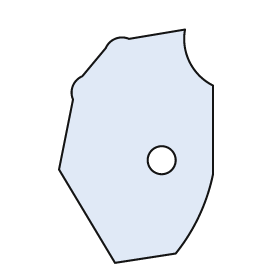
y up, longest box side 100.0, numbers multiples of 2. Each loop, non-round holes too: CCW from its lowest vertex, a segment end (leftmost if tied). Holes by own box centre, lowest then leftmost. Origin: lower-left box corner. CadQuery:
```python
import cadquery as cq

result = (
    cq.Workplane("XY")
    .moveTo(24.0, 0.0)
    .lineTo(50.0, 4.0)
    .threePointArc((60.0, 20.0), (66.0, 38.0))
    .lineTo(66.0, 76.0)
    .threePointArc((56.0, 86.0), (54.0, 100.0))
    .lineTo(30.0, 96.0)
    .threePointArc((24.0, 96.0), (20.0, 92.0))
    .lineTo(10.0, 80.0)
    .threePointArc((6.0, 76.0), (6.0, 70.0))
    .lineTo(0.0, 40.0)
    .close()
    .moveTo(44.0, 44.0)
    .circle(6.0)
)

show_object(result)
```